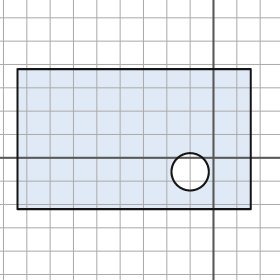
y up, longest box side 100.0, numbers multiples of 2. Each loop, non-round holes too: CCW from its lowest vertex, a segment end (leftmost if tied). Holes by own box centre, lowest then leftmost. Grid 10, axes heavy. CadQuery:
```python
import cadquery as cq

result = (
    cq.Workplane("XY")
    .moveTo(-84.0, -22.0)
    .lineTo(16.0, -22.0)
    .lineTo(16.0, 38.0)
    .lineTo(-84.0, 38.0)
    .close()
    .moveTo(-10.0, -6.0)
    .circle(8.0)
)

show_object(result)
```